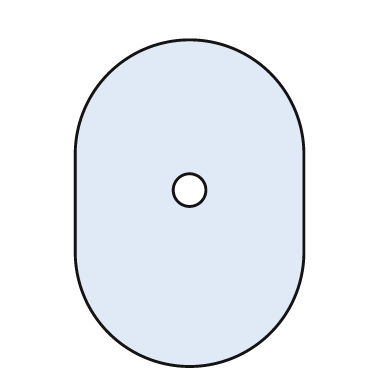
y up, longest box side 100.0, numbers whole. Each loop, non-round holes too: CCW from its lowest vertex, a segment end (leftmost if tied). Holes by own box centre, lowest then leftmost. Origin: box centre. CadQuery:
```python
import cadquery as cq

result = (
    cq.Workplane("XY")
    .moveTo(-35.0, -15.0)
    .threePointArc((0.0, -50.0), (35.0, -15.0))
    .lineTo(35.0, 15.0)
    .threePointArc((0.0, 50.0), (-35.0, 15.0))
    .close()
    .moveTo(0.0, 4.0)
    .circle(5.0)
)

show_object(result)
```